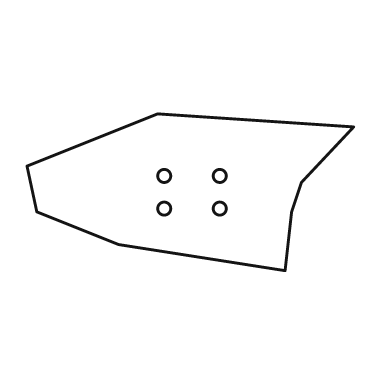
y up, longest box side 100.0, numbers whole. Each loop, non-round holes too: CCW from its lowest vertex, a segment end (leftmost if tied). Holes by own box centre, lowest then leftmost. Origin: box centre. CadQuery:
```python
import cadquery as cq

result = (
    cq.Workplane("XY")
    .moveTo(29.0, -24.0)
    .lineTo(31.0, -6.0)
    .lineTo(34.0, 3.0)
    .lineTo(50.0, 20.0)
    .lineTo(-10.0, 24.0)
    .lineTo(-50.0, 8.0)
    .lineTo(-47.0, -6.0)
    .lineTo(-22.0, -16.0)
    .close()
    .moveTo(-8.0, -5.0)
    .circle(2.0)
    .moveTo(9.0, -5.0)
    .circle(2.0)
    .moveTo(-8.0, 5.0)
    .circle(2.0)
    .moveTo(9.0, 5.0)
    .circle(2.0)
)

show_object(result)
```